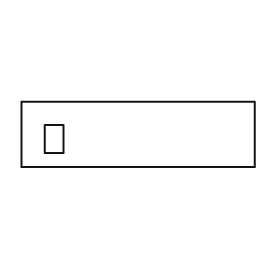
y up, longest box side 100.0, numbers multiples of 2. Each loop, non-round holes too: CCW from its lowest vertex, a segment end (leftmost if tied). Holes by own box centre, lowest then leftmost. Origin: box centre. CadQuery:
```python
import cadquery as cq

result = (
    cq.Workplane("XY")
    .moveTo(-50.0, -14.0)
    .lineTo(50.0, -14.0)
    .lineTo(50.0, 14.0)
    .lineTo(-50.0, 14.0)
    .close()
    .moveTo(-40.0, -8.0)
    .lineTo(-32.0, -8.0)
    .lineTo(-32.0, 4.0)
    .lineTo(-40.0, 4.0)
    .close()
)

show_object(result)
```